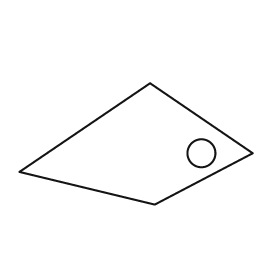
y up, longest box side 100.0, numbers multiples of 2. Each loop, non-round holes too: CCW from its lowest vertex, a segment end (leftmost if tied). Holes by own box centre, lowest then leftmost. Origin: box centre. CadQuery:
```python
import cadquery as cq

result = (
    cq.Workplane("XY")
    .moveTo(8.0, -26.0)
    .lineTo(50.0, -4.0)
    .lineTo(6.0, 26.0)
    .lineTo(-50.0, -12.0)
    .close()
    .moveTo(28.0, -4.0)
    .circle(6.0)
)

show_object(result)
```